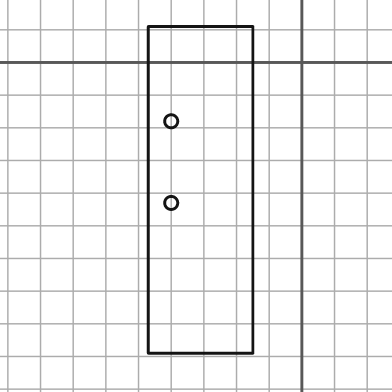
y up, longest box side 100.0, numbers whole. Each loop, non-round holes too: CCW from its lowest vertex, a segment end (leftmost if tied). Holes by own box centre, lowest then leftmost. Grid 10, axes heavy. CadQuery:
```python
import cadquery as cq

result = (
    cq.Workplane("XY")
    .moveTo(-47.0, -89.0)
    .lineTo(-15.0, -89.0)
    .lineTo(-15.0, 11.0)
    .lineTo(-47.0, 11.0)
    .close()
    .moveTo(-40.0, -43.0)
    .circle(2.0)
    .moveTo(-40.0, -18.0)
    .circle(2.0)
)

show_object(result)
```